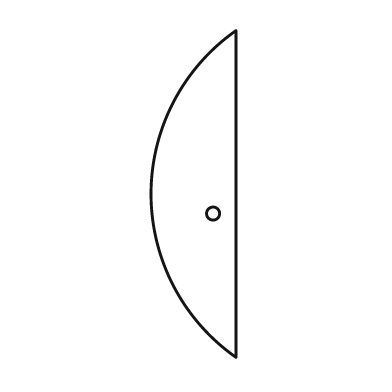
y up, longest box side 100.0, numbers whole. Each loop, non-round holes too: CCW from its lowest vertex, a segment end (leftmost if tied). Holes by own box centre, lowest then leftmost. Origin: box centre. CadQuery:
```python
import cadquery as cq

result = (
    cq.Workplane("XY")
    .moveTo(13.0, -50.0)
    .lineTo(13.0, 50.0)
    .threePointArc((-13.0, 0.0), (13.0, -50.0))
    .close()
    .moveTo(6.0, -6.0)
    .circle(2.0)
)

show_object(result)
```